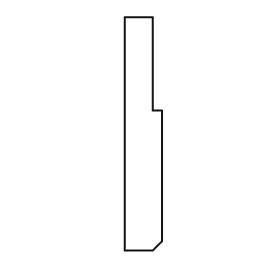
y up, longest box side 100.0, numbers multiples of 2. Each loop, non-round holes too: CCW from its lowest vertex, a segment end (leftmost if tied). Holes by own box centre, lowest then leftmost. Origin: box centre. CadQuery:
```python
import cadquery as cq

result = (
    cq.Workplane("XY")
    .moveTo(-8.0, -50.0)
    .lineTo(4.0, -50.0)
    .lineTo(8.0, -46.0)
    .lineTo(8.0, 10.0)
    .lineTo(4.0, 10.0)
    .lineTo(4.0, 50.0)
    .lineTo(-8.0, 50.0)
    .close()
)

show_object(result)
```